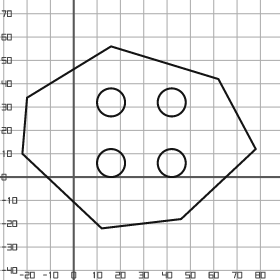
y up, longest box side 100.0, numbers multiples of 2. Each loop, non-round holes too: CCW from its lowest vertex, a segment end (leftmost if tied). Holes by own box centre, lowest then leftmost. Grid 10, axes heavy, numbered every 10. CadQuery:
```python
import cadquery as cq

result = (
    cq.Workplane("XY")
    .moveTo(12.0, -22.0)
    .lineTo(46.0, -18.0)
    .lineTo(78.0, 12.0)
    .lineTo(62.0, 42.0)
    .lineTo(16.0, 56.0)
    .lineTo(-20.0, 34.0)
    .lineTo(-22.0, 10.0)
    .close()
    .moveTo(16.0, 6.0)
    .circle(6.0)
    .moveTo(42.0, 6.0)
    .circle(6.0)
    .moveTo(16.0, 32.0)
    .circle(6.0)
    .moveTo(42.0, 32.0)
    .circle(6.0)
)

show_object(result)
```